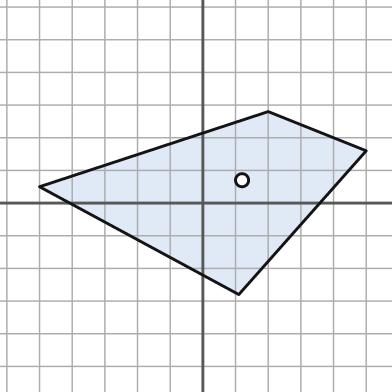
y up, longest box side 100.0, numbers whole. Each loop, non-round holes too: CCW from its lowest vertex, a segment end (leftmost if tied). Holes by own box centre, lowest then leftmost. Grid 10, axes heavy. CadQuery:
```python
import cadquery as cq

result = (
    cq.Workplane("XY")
    .moveTo(11.0, -28.0)
    .lineTo(50.0, 16.0)
    .lineTo(20.0, 28.0)
    .lineTo(-50.0, 5.0)
    .close()
    .moveTo(12.0, 7.0)
    .circle(2.0)
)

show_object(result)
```